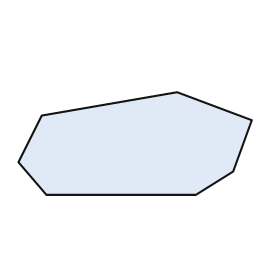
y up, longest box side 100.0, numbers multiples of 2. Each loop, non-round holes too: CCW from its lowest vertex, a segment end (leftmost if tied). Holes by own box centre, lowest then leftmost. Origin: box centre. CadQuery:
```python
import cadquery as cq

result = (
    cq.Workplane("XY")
    .moveTo(-38.0, -22.0)
    .lineTo(26.0, -22.0)
    .lineTo(42.0, -12.0)
    .lineTo(50.0, 10.0)
    .lineTo(18.0, 22.0)
    .lineTo(-40.0, 12.0)
    .lineTo(-50.0, -8.0)
    .close()
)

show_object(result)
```